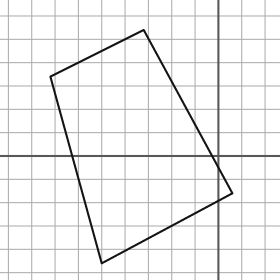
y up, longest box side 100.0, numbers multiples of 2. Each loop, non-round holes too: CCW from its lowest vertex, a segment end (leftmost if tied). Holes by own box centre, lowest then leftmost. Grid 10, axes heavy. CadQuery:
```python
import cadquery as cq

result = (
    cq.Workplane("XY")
    .moveTo(-50.0, -46.0)
    .lineTo(6.0, -16.0)
    .lineTo(-32.0, 54.0)
    .lineTo(-72.0, 34.0)
    .close()
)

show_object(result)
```